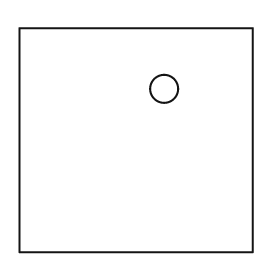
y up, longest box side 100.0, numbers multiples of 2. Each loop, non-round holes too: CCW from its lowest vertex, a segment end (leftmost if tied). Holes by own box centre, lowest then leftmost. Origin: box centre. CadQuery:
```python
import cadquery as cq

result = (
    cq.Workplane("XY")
    .moveTo(-50.0, -48.0)
    .lineTo(50.0, -48.0)
    .lineTo(50.0, 48.0)
    .lineTo(-50.0, 48.0)
    .close()
    .moveTo(12.0, 22.0)
    .circle(6.0)
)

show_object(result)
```